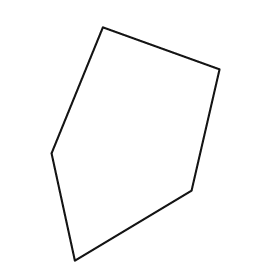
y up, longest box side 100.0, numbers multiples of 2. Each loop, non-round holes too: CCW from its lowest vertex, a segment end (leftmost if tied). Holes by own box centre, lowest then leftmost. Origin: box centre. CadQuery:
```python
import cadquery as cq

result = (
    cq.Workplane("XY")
    .moveTo(-26.0, -50.0)
    .lineTo(24.0, -20.0)
    .lineTo(36.0, 32.0)
    .lineTo(-14.0, 50.0)
    .lineTo(-36.0, -4.0)
    .close()
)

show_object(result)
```